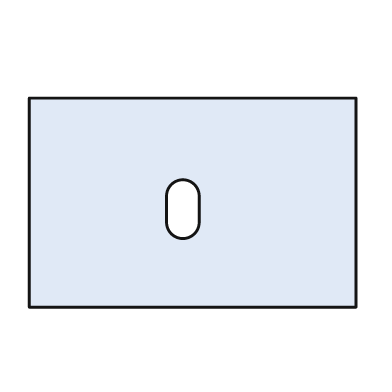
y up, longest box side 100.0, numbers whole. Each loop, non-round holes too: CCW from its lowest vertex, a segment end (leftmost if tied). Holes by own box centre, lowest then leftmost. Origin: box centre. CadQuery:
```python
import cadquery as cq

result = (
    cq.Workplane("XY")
    .moveTo(-50.0, -32.0)
    .lineTo(50.0, -32.0)
    .lineTo(50.0, 32.0)
    .lineTo(-50.0, 32.0)
    .close()
    .moveTo(-8.0, -6.0)
    .threePointArc((-3.0, -11.0), (2.0, -6.0))
    .lineTo(2.0, 2.0)
    .threePointArc((-3.0, 7.0), (-8.0, 2.0))
    .close()
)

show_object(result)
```